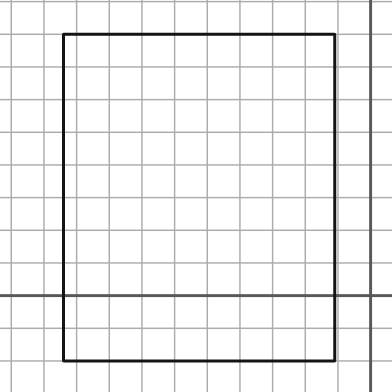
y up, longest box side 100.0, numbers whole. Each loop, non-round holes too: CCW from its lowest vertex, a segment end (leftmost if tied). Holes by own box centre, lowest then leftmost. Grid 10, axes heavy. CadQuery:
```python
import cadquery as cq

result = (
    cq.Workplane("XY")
    .moveTo(-94.0, -20.0)
    .lineTo(-11.0, -20.0)
    .lineTo(-11.0, 80.0)
    .lineTo(-94.0, 80.0)
    .close()
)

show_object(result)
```